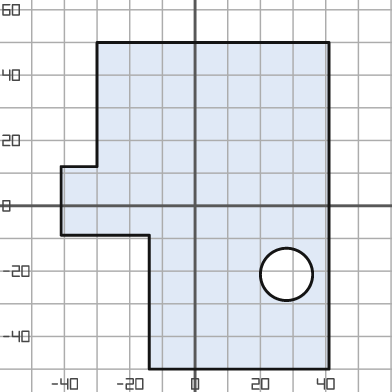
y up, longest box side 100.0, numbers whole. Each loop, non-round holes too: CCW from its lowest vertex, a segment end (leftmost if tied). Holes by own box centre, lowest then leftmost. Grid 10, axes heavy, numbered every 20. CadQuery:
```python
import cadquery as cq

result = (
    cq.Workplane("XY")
    .moveTo(-14.0, -50.0)
    .lineTo(41.0, -50.0)
    .lineTo(41.0, 50.0)
    .lineTo(-30.0, 50.0)
    .lineTo(-30.0, 12.0)
    .lineTo(-41.0, 12.0)
    .lineTo(-41.0, -9.0)
    .lineTo(-14.0, -9.0)
    .close()
    .moveTo(28.0, -21.0)
    .circle(8.0)
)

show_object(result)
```